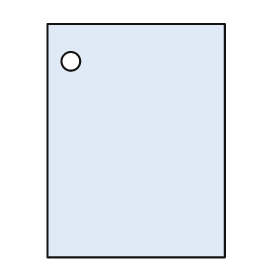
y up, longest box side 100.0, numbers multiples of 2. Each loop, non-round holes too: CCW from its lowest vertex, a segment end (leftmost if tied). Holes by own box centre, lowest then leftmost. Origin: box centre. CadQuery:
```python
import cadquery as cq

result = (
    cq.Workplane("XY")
    .moveTo(-38.0, -50.0)
    .lineTo(38.0, -50.0)
    .lineTo(38.0, 50.0)
    .lineTo(-38.0, 50.0)
    .close()
    .moveTo(-28.0, 34.0)
    .circle(4.0)
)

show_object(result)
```